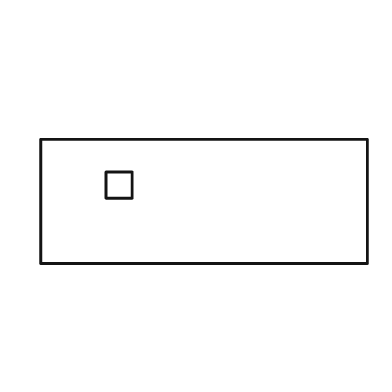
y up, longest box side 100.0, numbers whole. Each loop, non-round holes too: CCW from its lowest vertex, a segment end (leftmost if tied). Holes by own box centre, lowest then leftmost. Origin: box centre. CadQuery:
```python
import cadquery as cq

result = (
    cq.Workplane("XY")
    .moveTo(-50.0, -19.0)
    .lineTo(50.0, -19.0)
    .lineTo(50.0, 19.0)
    .lineTo(-50.0, 19.0)
    .close()
    .moveTo(-30.0, 1.0)
    .lineTo(-22.0, 1.0)
    .lineTo(-22.0, 9.0)
    .lineTo(-30.0, 9.0)
    .close()
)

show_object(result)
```